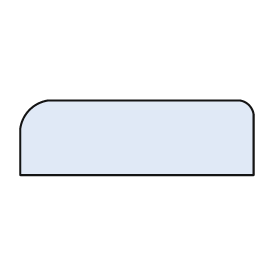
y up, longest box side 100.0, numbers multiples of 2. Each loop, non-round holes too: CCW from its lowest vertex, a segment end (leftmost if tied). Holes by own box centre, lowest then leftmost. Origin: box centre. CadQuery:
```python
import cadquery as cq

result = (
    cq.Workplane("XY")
    .moveTo(-50.0, -16.0)
    .lineTo(50.0, -16.0)
    .lineTo(50.0, 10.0)
    .threePointArc((48.0, 14.0), (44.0, 16.0))
    .lineTo(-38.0, 16.0)
    .threePointArc((-46.0, 12.0), (-50.0, 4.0))
    .close()
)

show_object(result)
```